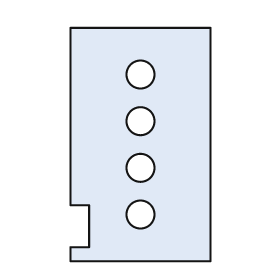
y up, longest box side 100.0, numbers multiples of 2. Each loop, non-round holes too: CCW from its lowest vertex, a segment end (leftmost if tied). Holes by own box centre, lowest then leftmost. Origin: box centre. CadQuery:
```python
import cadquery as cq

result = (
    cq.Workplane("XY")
    .moveTo(-30.0, -50.0)
    .lineTo(30.0, -50.0)
    .lineTo(30.0, 50.0)
    .lineTo(-30.0, 50.0)
    .lineTo(-30.0, -26.0)
    .lineTo(-22.0, -26.0)
    .lineTo(-22.0, -44.0)
    .lineTo(-30.0, -44.0)
    .close()
    .moveTo(0.0, -30.0)
    .circle(6.0)
    .moveTo(0.0, -10.0)
    .circle(6.0)
    .moveTo(0.0, 10.0)
    .circle(6.0)
    .moveTo(0.0, 30.0)
    .circle(6.0)
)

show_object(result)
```